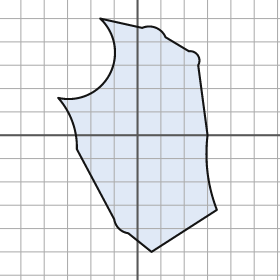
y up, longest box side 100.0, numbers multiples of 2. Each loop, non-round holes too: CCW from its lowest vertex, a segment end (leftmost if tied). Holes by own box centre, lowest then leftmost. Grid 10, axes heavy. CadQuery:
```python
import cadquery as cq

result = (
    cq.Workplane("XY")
    .moveTo(6.0, -50.0)
    .lineTo(34.0, -32.0)
    .threePointArc((30.0, -16.0), (30.0, 0.0))
    .lineTo(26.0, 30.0)
    .threePointArc((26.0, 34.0), (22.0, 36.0))
    .lineTo(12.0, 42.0)
    .threePointArc((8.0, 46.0), (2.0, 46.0))
    .lineTo(-16.0, 50.0)
    .threePointArc((-12.0, 26.0), (-34.0, 16.0))
    .threePointArc((-28.0, 6.0), (-26.0, -6.0))
    .lineTo(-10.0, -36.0)
    .threePointArc((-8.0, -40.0), (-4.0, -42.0))
    .close()
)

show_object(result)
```